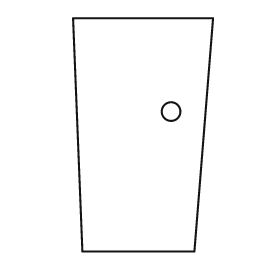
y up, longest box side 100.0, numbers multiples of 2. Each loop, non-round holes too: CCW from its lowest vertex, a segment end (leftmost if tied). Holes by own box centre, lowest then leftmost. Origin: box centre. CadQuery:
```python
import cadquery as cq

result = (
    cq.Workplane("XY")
    .moveTo(-26.0, -50.0)
    .lineTo(22.0, -50.0)
    .lineTo(30.0, 50.0)
    .lineTo(-30.0, 50.0)
    .close()
    .moveTo(12.0, 10.0)
    .circle(4.0)
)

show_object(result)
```